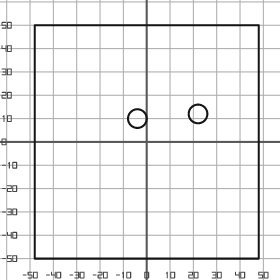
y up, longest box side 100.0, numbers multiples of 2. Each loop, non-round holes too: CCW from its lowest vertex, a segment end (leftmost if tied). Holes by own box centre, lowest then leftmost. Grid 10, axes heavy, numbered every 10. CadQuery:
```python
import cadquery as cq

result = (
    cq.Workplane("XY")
    .moveTo(-48.0, -50.0)
    .lineTo(48.0, -50.0)
    .lineTo(48.0, 50.0)
    .lineTo(-48.0, 50.0)
    .close()
    .moveTo(-4.0, 10.0)
    .circle(4.0)
    .moveTo(22.0, 12.0)
    .circle(4.0)
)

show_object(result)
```